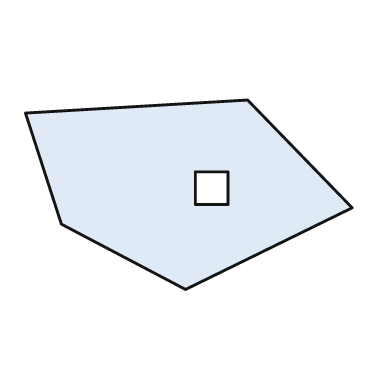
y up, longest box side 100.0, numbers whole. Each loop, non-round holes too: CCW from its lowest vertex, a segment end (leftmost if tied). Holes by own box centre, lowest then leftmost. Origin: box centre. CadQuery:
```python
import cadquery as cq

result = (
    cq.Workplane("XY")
    .moveTo(-1.0, -29.0)
    .lineTo(50.0, -4.0)
    .lineTo(18.0, 29.0)
    .lineTo(-50.0, 25.0)
    .lineTo(-39.0, -9.0)
    .close()
    .moveTo(2.0, -3.0)
    .lineTo(12.0, -3.0)
    .lineTo(12.0, 7.0)
    .lineTo(2.0, 7.0)
    .close()
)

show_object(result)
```